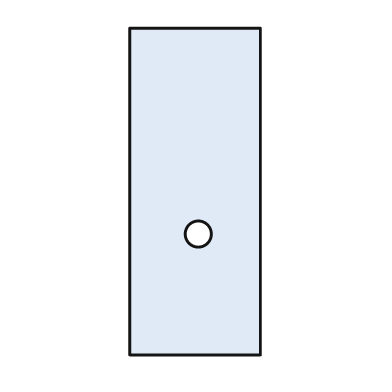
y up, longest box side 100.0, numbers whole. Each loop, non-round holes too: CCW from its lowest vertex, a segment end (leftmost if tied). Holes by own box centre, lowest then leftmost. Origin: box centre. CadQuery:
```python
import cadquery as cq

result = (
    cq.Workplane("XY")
    .moveTo(-20.0, -50.0)
    .lineTo(20.0, -50.0)
    .lineTo(20.0, 50.0)
    .lineTo(-20.0, 50.0)
    .close()
    .moveTo(1.0, -13.0)
    .circle(4.0)
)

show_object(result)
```